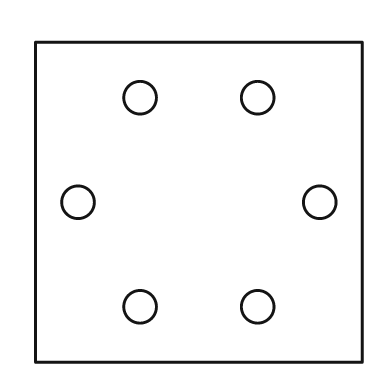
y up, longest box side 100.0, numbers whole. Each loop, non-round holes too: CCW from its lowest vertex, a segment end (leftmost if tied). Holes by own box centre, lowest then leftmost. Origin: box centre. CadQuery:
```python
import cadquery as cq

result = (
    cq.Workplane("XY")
    .moveTo(-50.0, -49.0)
    .lineTo(50.0, -49.0)
    .lineTo(50.0, 49.0)
    .lineTo(-50.0, 49.0)
    .close()
    .moveTo(-18.0, -32.0)
    .circle(5.0)
    .moveTo(18.0, -32.0)
    .circle(5.0)
    .moveTo(-37.0, 0.0)
    .circle(5.0)
    .moveTo(37.0, 0.0)
    .circle(5.0)
    .moveTo(-18.0, 32.0)
    .circle(5.0)
    .moveTo(18.0, 32.0)
    .circle(5.0)
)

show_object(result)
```